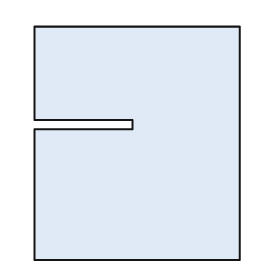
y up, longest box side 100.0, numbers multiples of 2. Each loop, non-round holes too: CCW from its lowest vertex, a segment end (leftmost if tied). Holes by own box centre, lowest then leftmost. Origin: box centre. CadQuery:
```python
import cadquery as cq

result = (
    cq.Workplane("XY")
    .moveTo(-44.0, -50.0)
    .lineTo(44.0, -50.0)
    .lineTo(44.0, 50.0)
    .lineTo(-44.0, 50.0)
    .lineTo(-44.0, 10.0)
    .lineTo(-2.0, 10.0)
    .lineTo(-2.0, 6.0)
    .lineTo(-44.0, 6.0)
    .close()
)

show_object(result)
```